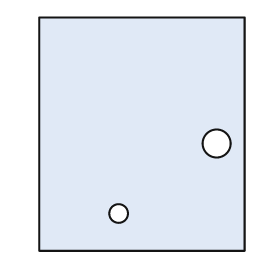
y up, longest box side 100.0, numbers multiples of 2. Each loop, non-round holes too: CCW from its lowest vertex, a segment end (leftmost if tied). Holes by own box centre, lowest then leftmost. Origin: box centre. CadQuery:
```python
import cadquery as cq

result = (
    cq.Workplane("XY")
    .moveTo(-44.0, -50.0)
    .lineTo(44.0, -50.0)
    .lineTo(44.0, 50.0)
    .lineTo(-44.0, 50.0)
    .close()
    .moveTo(-10.0, -34.0)
    .circle(4.0)
    .moveTo(32.0, -4.0)
    .circle(6.0)
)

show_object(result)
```